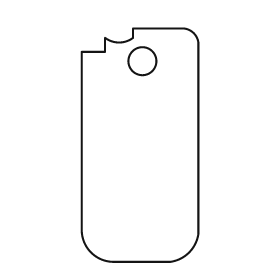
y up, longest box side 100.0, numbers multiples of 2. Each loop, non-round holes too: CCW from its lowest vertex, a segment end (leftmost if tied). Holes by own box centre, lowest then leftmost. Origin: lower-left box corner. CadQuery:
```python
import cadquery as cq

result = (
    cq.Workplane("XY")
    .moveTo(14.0, 0.0)
    .lineTo(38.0, 0.0)
    .threePointArc((46.0, 4.0), (50.0, 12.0))
    .lineTo(50.0, 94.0)
    .threePointArc((48.0, 98.0), (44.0, 100.0))
    .lineTo(22.0, 100.0)
    .lineTo(22.0, 96.0)
    .threePointArc((16.0, 94.0), (10.0, 96.0))
    .lineTo(10.0, 90.0)
    .lineTo(0.0, 90.0)
    .lineTo(0.0, 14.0)
    .threePointArc((4.0, 4.0), (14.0, 0.0))
    .close()
    .moveTo(26.0, 86.0)
    .circle(6.0)
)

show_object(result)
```